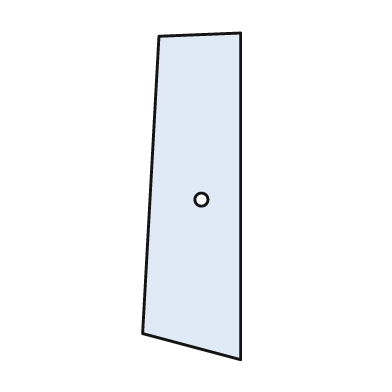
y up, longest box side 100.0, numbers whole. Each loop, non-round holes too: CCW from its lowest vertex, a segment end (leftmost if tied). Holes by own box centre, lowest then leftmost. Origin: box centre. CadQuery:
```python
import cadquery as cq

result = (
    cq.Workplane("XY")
    .moveTo(15.0, -50.0)
    .lineTo(15.0, 50.0)
    .lineTo(-10.0, 49.0)
    .lineTo(-15.0, -42.0)
    .close()
    .moveTo(3.0, -1.0)
    .circle(2.0)
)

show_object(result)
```